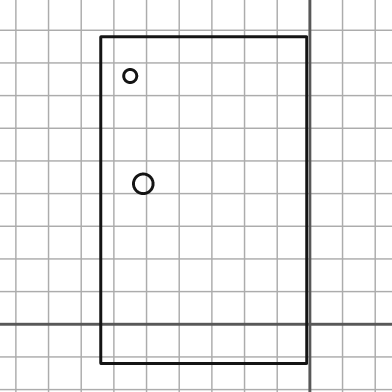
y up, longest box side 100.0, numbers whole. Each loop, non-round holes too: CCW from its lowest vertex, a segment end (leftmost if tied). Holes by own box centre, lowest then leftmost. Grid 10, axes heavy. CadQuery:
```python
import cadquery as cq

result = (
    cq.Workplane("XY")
    .moveTo(-64.0, -12.0)
    .lineTo(-1.0, -12.0)
    .lineTo(-1.0, 88.0)
    .lineTo(-64.0, 88.0)
    .close()
    .moveTo(-51.0, 43.0)
    .circle(3.0)
    .moveTo(-55.0, 76.0)
    .circle(2.0)
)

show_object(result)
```